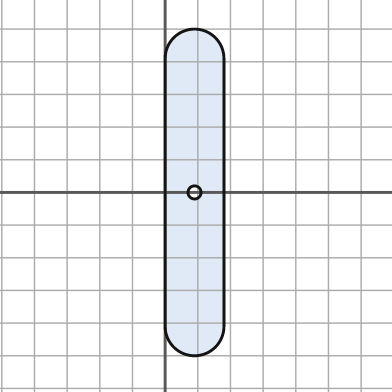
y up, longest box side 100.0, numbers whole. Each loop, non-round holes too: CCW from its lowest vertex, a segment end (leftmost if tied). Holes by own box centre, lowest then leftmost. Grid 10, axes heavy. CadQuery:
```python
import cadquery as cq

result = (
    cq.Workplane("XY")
    .moveTo(0.0, -41.0)
    .threePointArc((9.0, -50.0), (18.0, -41.0))
    .lineTo(18.0, 41.0)
    .threePointArc((9.0, 50.0), (0.0, 41.0))
    .close()
    .moveTo(9.0, 0.0)
    .circle(2.0)
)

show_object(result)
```